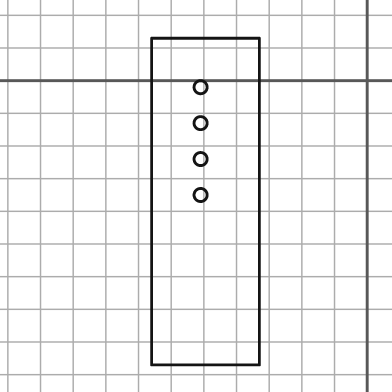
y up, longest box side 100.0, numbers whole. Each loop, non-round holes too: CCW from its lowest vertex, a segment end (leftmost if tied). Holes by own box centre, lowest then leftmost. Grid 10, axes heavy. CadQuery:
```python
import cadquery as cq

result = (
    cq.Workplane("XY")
    .moveTo(-66.0, -87.0)
    .lineTo(-33.0, -87.0)
    .lineTo(-33.0, 13.0)
    .lineTo(-66.0, 13.0)
    .close()
    .moveTo(-51.0, -35.0)
    .circle(2.0)
    .moveTo(-51.0, -24.0)
    .circle(2.0)
    .moveTo(-51.0, -13.0)
    .circle(2.0)
    .moveTo(-51.0, -2.0)
    .circle(2.0)
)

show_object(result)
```